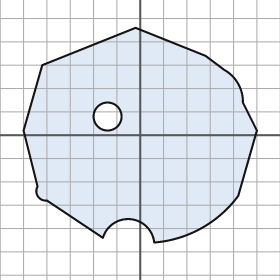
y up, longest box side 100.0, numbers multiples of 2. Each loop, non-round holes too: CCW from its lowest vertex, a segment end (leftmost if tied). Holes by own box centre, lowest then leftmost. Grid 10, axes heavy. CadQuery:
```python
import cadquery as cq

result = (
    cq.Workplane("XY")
    .moveTo(6.0, -46.0)
    .threePointArc((26.0, -40.0), (42.0, -26.0))
    .lineTo(50.0, 2.0)
    .lineTo(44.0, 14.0)
    .threePointArc((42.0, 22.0), (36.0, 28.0))
    .lineTo(28.0, 34.0)
    .lineTo(-2.0, 46.0)
    .lineTo(-42.0, 30.0)
    .lineTo(-50.0, 2.0)
    .lineTo(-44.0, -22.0)
    .threePointArc((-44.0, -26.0), (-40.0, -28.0))
    .lineTo(-16.0, -44.0)
    .threePointArc((-4.0, -36.0), (6.0, -46.0))
    .close()
    .moveTo(-14.0, 8.0)
    .circle(6.0)
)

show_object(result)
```